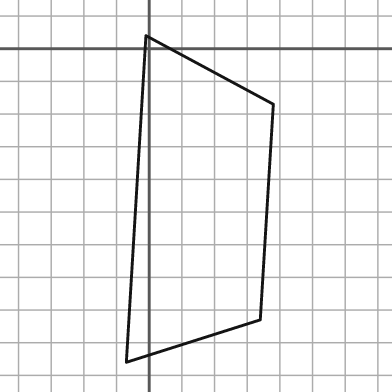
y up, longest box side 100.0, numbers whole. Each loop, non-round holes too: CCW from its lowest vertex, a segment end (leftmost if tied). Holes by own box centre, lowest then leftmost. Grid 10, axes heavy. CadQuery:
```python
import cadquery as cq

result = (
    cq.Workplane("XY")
    .moveTo(-7.0, -96.0)
    .lineTo(34.0, -83.0)
    .lineTo(38.0, -17.0)
    .lineTo(-1.0, 4.0)
    .close()
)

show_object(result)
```